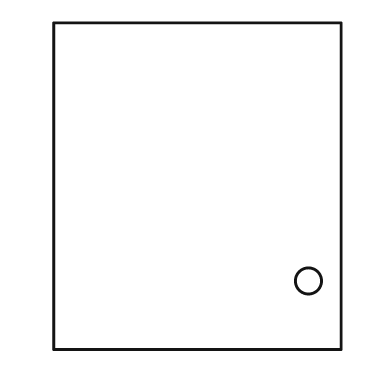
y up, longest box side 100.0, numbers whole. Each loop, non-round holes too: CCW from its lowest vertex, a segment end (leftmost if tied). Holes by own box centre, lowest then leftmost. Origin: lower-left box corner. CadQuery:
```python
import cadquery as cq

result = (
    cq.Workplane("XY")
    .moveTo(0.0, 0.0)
    .lineTo(88.0, 0.0)
    .lineTo(88.0, 100.0)
    .lineTo(0.0, 100.0)
    .close()
    .moveTo(78.0, 21.0)
    .circle(4.0)
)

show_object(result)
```